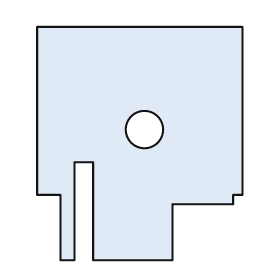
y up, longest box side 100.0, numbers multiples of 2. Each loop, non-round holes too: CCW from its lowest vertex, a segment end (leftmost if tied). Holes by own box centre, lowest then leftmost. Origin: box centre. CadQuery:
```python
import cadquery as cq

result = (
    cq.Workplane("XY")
    .moveTo(-34.0, -50.0)
    .lineTo(-28.0, -50.0)
    .lineTo(-28.0, -8.0)
    .lineTo(-20.0, -8.0)
    .lineTo(-20.0, -50.0)
    .lineTo(14.0, -50.0)
    .lineTo(14.0, -26.0)
    .lineTo(40.0, -26.0)
    .lineTo(40.0, -22.0)
    .lineTo(44.0, -22.0)
    .lineTo(44.0, 50.0)
    .lineTo(-44.0, 50.0)
    .lineTo(-44.0, -22.0)
    .lineTo(-34.0, -22.0)
    .close()
    .moveTo(2.0, 6.0)
    .circle(8.0)
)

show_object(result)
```